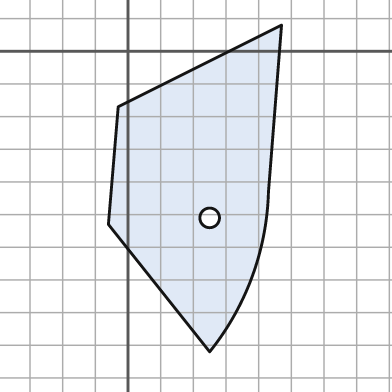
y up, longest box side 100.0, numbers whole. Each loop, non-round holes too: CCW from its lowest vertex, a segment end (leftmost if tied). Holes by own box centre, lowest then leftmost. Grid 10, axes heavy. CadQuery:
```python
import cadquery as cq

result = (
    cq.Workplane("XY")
    .moveTo(25.0, -92.0)
    .threePointArc((38.0, -69.0), (43.0, -43.0))
    .lineTo(47.0, 8.0)
    .lineTo(-3.0, -17.0)
    .lineTo(-6.0, -53.0)
    .close()
    .moveTo(25.0, -51.0)
    .circle(3.0)
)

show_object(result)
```